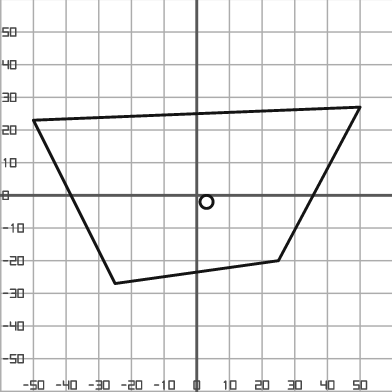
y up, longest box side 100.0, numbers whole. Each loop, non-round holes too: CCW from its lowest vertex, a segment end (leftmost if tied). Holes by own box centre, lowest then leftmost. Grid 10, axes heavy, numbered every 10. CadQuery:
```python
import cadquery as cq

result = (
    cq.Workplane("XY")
    .moveTo(-25.0, -27.0)
    .lineTo(25.0, -20.0)
    .lineTo(50.0, 27.0)
    .lineTo(-50.0, 23.0)
    .close()
    .moveTo(3.0, -2.0)
    .circle(2.0)
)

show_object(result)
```